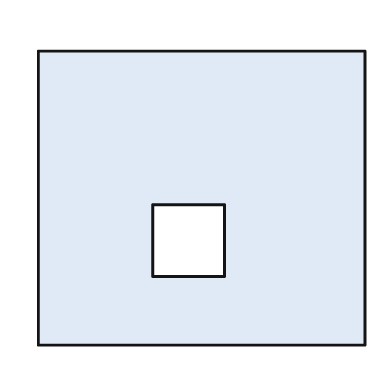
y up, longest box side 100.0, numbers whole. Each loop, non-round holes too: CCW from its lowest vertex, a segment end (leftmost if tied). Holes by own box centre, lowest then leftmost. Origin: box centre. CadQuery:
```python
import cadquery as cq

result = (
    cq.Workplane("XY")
    .moveTo(-50.0, -45.0)
    .lineTo(50.0, -45.0)
    .lineTo(50.0, 45.0)
    .lineTo(-50.0, 45.0)
    .close()
    .moveTo(-15.0, -24.0)
    .lineTo(7.0, -24.0)
    .lineTo(7.0, -2.0)
    .lineTo(-15.0, -2.0)
    .close()
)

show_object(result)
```